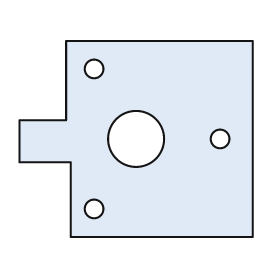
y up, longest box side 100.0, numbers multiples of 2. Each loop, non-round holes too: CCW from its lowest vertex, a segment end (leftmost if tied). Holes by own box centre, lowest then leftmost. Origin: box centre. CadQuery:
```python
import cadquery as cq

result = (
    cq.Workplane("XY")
    .moveTo(-28.0, -42.0)
    .lineTo(50.0, -42.0)
    .lineTo(50.0, 42.0)
    .lineTo(-30.0, 42.0)
    .lineTo(-30.0, 8.0)
    .lineTo(-50.0, 8.0)
    .lineTo(-50.0, -10.0)
    .lineTo(-28.0, -10.0)
    .close()
    .moveTo(-18.0, -30.0)
    .circle(4.0)
    .moveTo(0.0, 0.0)
    .circle(12.0)
    .moveTo(36.0, 0.0)
    .circle(4.0)
    .moveTo(-18.0, 30.0)
    .circle(4.0)
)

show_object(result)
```